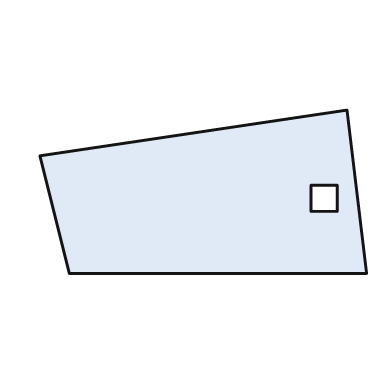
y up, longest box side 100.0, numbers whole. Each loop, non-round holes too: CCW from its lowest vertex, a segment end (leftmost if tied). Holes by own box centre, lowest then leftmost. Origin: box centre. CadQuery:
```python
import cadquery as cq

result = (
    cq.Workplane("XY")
    .moveTo(-41.0, -25.0)
    .lineTo(50.0, -25.0)
    .lineTo(44.0, 25.0)
    .lineTo(-50.0, 11.0)
    .close()
    .moveTo(33.0, -6.0)
    .lineTo(41.0, -6.0)
    .lineTo(41.0, 2.0)
    .lineTo(33.0, 2.0)
    .close()
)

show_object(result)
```